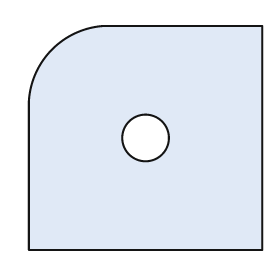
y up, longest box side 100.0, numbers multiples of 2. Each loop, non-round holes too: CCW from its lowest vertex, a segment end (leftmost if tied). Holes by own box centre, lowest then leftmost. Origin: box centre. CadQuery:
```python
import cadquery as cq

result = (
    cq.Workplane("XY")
    .moveTo(-50.0, -48.0)
    .lineTo(50.0, -48.0)
    .lineTo(50.0, 48.0)
    .lineTo(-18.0, 48.0)
    .threePointArc((-40.0, 38.0), (-50.0, 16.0))
    .close()
    .moveTo(0.0, 0.0)
    .circle(10.0)
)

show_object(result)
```